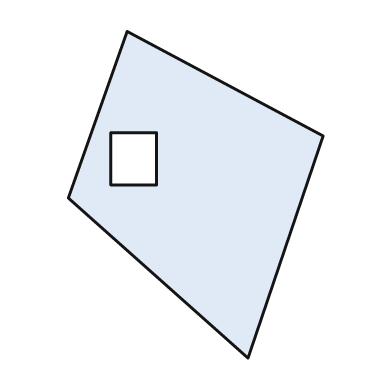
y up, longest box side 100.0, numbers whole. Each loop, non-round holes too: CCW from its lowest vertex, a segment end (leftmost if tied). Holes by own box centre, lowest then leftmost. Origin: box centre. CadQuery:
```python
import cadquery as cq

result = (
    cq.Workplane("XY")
    .moveTo(16.0, -50.0)
    .lineTo(39.0, 18.0)
    .lineTo(-21.0, 50.0)
    .lineTo(-39.0, -1.0)
    .close()
    .moveTo(-26.0, 3.0)
    .lineTo(-12.0, 3.0)
    .lineTo(-12.0, 19.0)
    .lineTo(-26.0, 19.0)
    .close()
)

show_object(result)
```